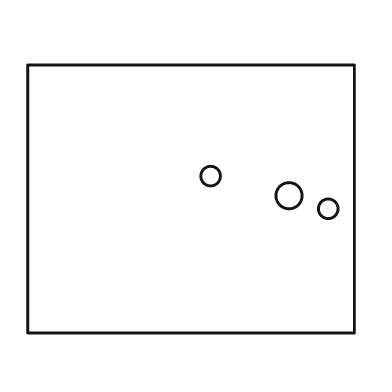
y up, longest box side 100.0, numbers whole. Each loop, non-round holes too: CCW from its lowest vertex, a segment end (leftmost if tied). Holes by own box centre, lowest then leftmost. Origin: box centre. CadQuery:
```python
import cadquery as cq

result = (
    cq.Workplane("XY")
    .moveTo(-50.0, -41.0)
    .lineTo(50.0, -41.0)
    .lineTo(50.0, 41.0)
    .lineTo(-50.0, 41.0)
    .close()
    .moveTo(42.0, -3.0)
    .circle(3.0)
    .moveTo(30.0, 1.0)
    .circle(4.0)
    .moveTo(6.0, 7.0)
    .circle(3.0)
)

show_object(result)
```